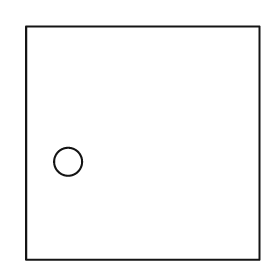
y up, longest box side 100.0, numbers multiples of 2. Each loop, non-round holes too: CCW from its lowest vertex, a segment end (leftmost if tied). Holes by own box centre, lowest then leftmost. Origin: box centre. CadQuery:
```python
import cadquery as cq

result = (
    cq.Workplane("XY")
    .moveTo(-50.0, -50.0)
    .lineTo(50.0, -50.0)
    .lineTo(50.0, 50.0)
    .lineTo(-50.0, 50.0)
    .close()
    .moveTo(-32.0, -8.0)
    .circle(6.0)
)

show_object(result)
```